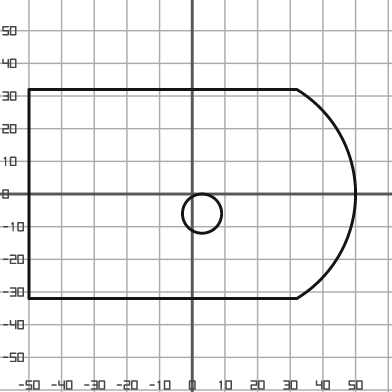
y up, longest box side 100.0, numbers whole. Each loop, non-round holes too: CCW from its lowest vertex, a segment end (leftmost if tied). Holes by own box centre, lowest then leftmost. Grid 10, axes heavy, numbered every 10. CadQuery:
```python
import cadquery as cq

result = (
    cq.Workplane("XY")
    .moveTo(-50.0, -32.0)
    .lineTo(32.0, -32.0)
    .threePointArc((50.0, 0.0), (32.0, 32.0))
    .lineTo(-50.0, 32.0)
    .close()
    .moveTo(3.0, -6.0)
    .circle(6.0)
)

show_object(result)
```